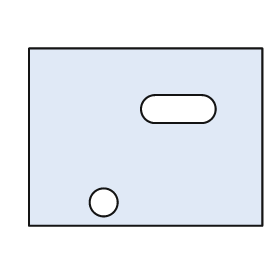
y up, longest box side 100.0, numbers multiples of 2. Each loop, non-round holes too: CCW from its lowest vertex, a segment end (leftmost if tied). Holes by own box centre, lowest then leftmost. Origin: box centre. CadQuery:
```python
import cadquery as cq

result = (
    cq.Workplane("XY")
    .moveTo(-50.0, -38.0)
    .lineTo(50.0, -38.0)
    .lineTo(50.0, 38.0)
    .lineTo(-50.0, 38.0)
    .close()
    .moveTo(-18.0, -28.0)
    .circle(6.0)
    .moveTo(4.0, 6.0)
    .lineTo(24.0, 6.0)
    .threePointArc((30.0, 12.0), (24.0, 18.0))
    .lineTo(4.0, 18.0)
    .threePointArc((-2.0, 12.0), (4.0, 6.0))
    .close()
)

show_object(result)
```